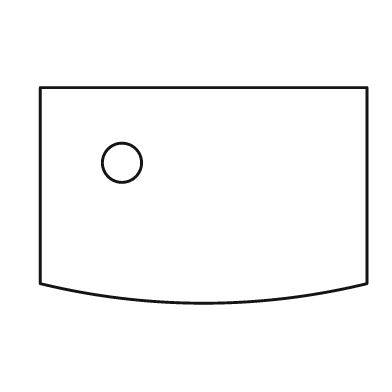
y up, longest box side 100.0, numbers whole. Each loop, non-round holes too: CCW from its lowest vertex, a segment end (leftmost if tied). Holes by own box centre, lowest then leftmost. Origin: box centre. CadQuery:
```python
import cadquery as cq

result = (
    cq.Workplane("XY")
    .moveTo(-50.0, -27.0)
    .threePointArc((0.0, -33.0), (50.0, -27.0))
    .lineTo(50.0, 33.0)
    .lineTo(-50.0, 33.0)
    .close()
    .moveTo(-25.0, 10.0)
    .circle(6.0)
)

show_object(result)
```